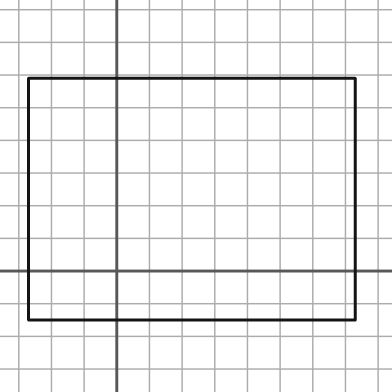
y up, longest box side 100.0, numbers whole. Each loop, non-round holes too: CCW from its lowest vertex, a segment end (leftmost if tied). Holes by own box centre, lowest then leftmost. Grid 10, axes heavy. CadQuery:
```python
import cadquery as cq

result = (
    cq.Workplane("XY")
    .moveTo(-27.0, -15.0)
    .lineTo(73.0, -15.0)
    .lineTo(73.0, 59.0)
    .lineTo(-27.0, 59.0)
    .close()
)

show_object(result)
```